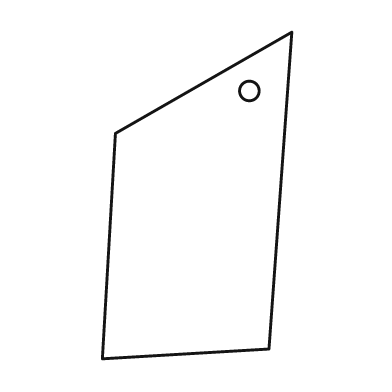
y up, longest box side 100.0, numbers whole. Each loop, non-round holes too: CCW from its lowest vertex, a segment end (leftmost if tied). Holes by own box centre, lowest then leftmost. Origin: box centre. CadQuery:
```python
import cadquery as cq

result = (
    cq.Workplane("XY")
    .moveTo(-29.0, -50.0)
    .lineTo(22.0, -47.0)
    .lineTo(29.0, 50.0)
    .lineTo(-25.0, 19.0)
    .close()
    .moveTo(16.0, 32.0)
    .circle(3.0)
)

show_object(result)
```